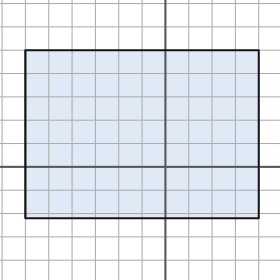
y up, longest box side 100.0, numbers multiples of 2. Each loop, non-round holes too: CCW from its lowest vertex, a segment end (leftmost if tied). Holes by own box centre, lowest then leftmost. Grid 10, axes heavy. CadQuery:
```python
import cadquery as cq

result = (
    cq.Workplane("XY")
    .moveTo(-60.0, -22.0)
    .lineTo(40.0, -22.0)
    .lineTo(40.0, 50.0)
    .lineTo(-60.0, 50.0)
    .close()
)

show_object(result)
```